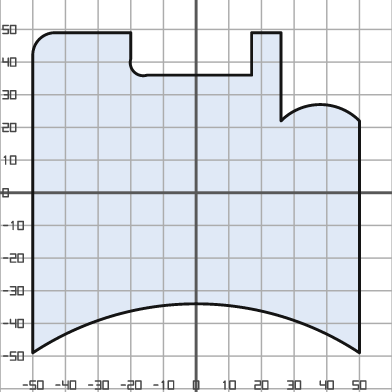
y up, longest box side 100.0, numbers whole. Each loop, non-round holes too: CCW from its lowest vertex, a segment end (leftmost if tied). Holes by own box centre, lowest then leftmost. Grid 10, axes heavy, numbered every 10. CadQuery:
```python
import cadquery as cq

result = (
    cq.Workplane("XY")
    .moveTo(-50.0, -49.0)
    .threePointArc((0.0, -34.0), (50.0, -49.0))
    .lineTo(50.0, 22.0)
    .threePointArc((38.0, 27.0), (26.0, 22.0))
    .lineTo(26.0, 49.0)
    .lineTo(17.0, 49.0)
    .lineTo(17.0, 36.0)
    .lineTo(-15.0, 36.0)
    .threePointArc((-19.0, 37.0), (-20.0, 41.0))
    .lineTo(-20.0, 49.0)
    .lineTo(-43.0, 49.0)
    .threePointArc((-48.0, 47.0), (-50.0, 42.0))
    .close()
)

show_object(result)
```